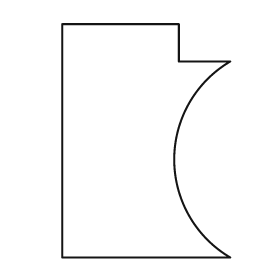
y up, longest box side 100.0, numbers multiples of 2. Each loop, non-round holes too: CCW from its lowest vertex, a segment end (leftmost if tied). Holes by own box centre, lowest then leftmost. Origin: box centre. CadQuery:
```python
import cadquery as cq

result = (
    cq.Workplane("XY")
    .moveTo(-36.0, -50.0)
    .lineTo(36.0, -50.0)
    .threePointArc((12.0, -8.0), (36.0, 34.0))
    .lineTo(14.0, 34.0)
    .lineTo(14.0, 50.0)
    .lineTo(-36.0, 50.0)
    .close()
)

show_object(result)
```